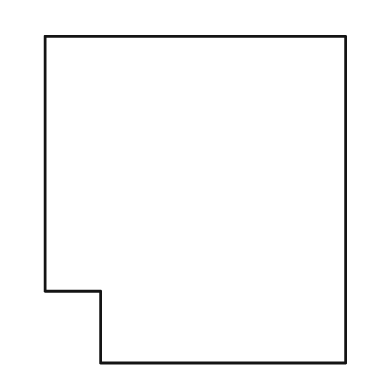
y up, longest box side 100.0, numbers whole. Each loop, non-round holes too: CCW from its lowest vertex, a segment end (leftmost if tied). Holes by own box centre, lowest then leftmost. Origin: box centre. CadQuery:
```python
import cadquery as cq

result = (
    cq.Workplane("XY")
    .moveTo(-29.0, -50.0)
    .lineTo(46.0, -50.0)
    .lineTo(46.0, 50.0)
    .lineTo(-46.0, 50.0)
    .lineTo(-46.0, -28.0)
    .lineTo(-29.0, -28.0)
    .close()
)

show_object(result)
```